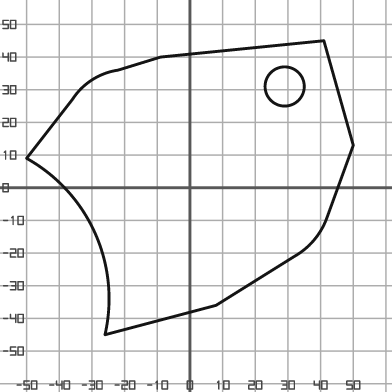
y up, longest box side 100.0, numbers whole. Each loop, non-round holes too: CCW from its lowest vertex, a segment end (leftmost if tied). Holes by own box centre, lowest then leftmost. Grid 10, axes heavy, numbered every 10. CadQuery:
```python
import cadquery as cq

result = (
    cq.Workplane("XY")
    .moveTo(-26.0, -45.0)
    .lineTo(8.0, -36.0)
    .lineTo(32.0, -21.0)
    .threePointArc((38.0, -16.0), (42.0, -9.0))
    .lineTo(50.0, 13.0)
    .lineTo(41.0, 45.0)
    .lineTo(-9.0, 40.0)
    .lineTo(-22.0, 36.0)
    .threePointArc((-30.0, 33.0), (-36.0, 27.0))
    .lineTo(-50.0, 9.0)
    .threePointArc((-29.0, -14.0), (-26.0, -45.0))
    .close()
    .moveTo(29.0, 31.0)
    .circle(6.0)
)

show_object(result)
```